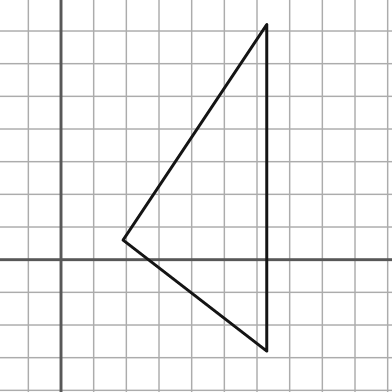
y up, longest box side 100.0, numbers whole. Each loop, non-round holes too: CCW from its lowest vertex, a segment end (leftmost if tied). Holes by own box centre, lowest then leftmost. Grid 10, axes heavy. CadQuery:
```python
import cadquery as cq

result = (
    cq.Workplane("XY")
    .moveTo(63.0, -28.0)
    .lineTo(63.0, 72.0)
    .lineTo(19.0, 6.0)
    .close()
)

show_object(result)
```